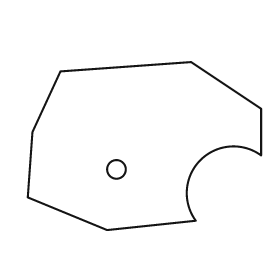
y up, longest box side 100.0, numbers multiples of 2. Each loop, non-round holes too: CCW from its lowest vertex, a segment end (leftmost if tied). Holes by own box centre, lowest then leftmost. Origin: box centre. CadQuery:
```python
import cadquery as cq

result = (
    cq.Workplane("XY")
    .moveTo(-16.0, -36.0)
    .lineTo(22.0, -32.0)
    .threePointArc((24.0, -6.0), (50.0, -4.0))
    .lineTo(50.0, 16.0)
    .lineTo(20.0, 36.0)
    .lineTo(-36.0, 32.0)
    .lineTo(-48.0, 6.0)
    .lineTo(-50.0, -22.0)
    .close()
    .moveTo(-12.0, -10.0)
    .circle(4.0)
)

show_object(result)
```